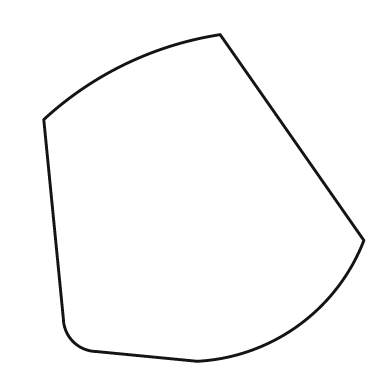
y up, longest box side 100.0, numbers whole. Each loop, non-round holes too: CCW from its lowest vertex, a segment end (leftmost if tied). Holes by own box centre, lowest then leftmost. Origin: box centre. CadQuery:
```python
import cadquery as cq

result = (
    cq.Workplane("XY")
    .moveTo(-2.0, -50.0)
    .threePointArc((29.0, -39.0), (49.0, -13.0))
    .lineTo(5.0, 50.0)
    .threePointArc((-24.0, 41.0), (-49.0, 24.0))
    .lineTo(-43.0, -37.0)
    .threePointArc((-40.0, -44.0), (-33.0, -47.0))
    .close()
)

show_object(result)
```